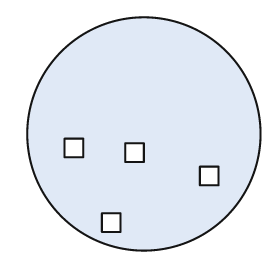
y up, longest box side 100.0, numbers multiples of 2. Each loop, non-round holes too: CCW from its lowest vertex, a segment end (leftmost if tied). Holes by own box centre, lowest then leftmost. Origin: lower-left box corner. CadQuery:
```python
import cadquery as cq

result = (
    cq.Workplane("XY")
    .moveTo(50.0, 50.0)
    .circle(50.0)
    .moveTo(32.0, 8.0)
    .lineTo(40.0, 8.0)
    .lineTo(40.0, 16.0)
    .lineTo(32.0, 16.0)
    .close()
    .moveTo(74.0, 28.0)
    .lineTo(82.0, 28.0)
    .lineTo(82.0, 36.0)
    .lineTo(74.0, 36.0)
    .close()
    .moveTo(42.0, 38.0)
    .lineTo(50.0, 38.0)
    .lineTo(50.0, 46.0)
    .lineTo(42.0, 46.0)
    .close()
    .moveTo(16.0, 40.0)
    .lineTo(24.0, 40.0)
    .lineTo(24.0, 48.0)
    .lineTo(16.0, 48.0)
    .close()
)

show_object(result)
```